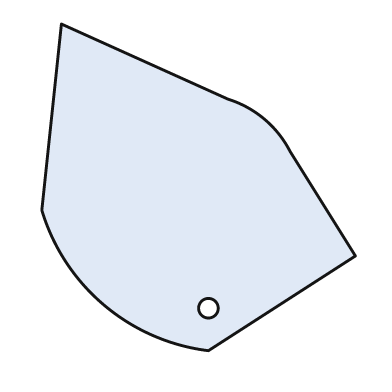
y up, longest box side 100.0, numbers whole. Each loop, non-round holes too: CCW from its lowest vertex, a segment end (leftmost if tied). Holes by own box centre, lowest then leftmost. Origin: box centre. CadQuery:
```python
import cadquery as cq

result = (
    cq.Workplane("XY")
    .moveTo(3.0, -50.0)
    .lineTo(48.0, -21.0)
    .lineTo(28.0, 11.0)
    .threePointArc((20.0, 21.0), (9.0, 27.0))
    .lineTo(-42.0, 50.0)
    .lineTo(-48.0, -7.0)
    .threePointArc((-29.0, -36.0), (3.0, -50.0))
    .close()
    .moveTo(3.0, -37.0)
    .circle(3.0)
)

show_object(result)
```